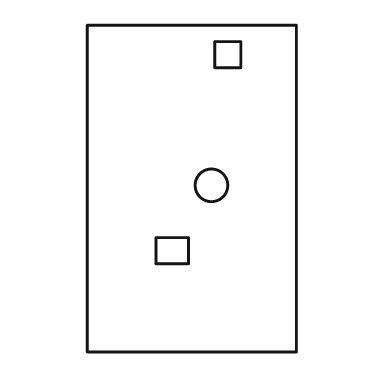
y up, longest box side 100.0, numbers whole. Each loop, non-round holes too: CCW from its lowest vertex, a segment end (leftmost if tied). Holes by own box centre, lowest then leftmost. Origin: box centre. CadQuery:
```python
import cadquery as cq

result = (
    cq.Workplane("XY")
    .moveTo(-32.0, -50.0)
    .lineTo(32.0, -50.0)
    .lineTo(32.0, 50.0)
    .lineTo(-32.0, 50.0)
    .close()
    .moveTo(-11.0, -23.0)
    .lineTo(-1.0, -23.0)
    .lineTo(-1.0, -15.0)
    .lineTo(-11.0, -15.0)
    .close()
    .moveTo(6.0, 1.0)
    .circle(5.0)
    .moveTo(7.0, 37.0)
    .lineTo(15.0, 37.0)
    .lineTo(15.0, 45.0)
    .lineTo(7.0, 45.0)
    .close()
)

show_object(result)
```